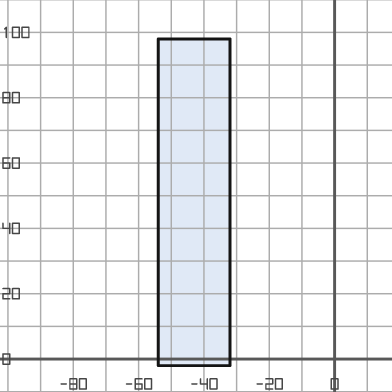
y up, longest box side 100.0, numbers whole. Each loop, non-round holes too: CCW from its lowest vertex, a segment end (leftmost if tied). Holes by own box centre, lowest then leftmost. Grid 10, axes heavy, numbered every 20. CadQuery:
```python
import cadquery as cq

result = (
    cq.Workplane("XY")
    .moveTo(-54.0, -2.0)
    .lineTo(-32.0, -2.0)
    .lineTo(-32.0, 98.0)
    .lineTo(-54.0, 98.0)
    .close()
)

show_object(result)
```